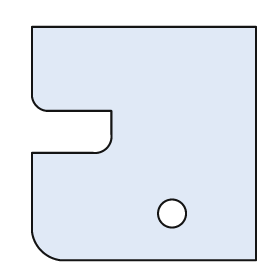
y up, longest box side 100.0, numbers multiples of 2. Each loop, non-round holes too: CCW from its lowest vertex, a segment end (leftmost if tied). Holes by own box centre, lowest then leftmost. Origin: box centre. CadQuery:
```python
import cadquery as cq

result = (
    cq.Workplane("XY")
    .moveTo(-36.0, -50.0)
    .lineTo(48.0, -50.0)
    .lineTo(48.0, 50.0)
    .lineTo(-48.0, 50.0)
    .lineTo(-48.0, 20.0)
    .threePointArc((-46.0, 16.0), (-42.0, 14.0))
    .lineTo(-14.0, 14.0)
    .lineTo(-14.0, 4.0)
    .threePointArc((-16.0, -2.0), (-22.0, -4.0))
    .lineTo(-48.0, -4.0)
    .lineTo(-48.0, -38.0)
    .threePointArc((-44.0, -46.0), (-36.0, -50.0))
    .close()
    .moveTo(12.0, -30.0)
    .circle(6.0)
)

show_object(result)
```